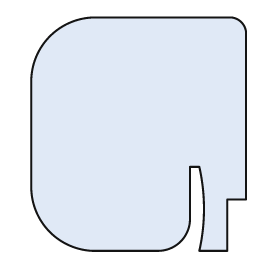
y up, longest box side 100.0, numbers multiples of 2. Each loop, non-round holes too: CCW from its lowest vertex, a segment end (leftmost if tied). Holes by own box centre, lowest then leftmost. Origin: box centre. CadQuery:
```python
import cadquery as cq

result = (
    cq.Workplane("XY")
    .moveTo(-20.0, -50.0)
    .lineTo(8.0, -50.0)
    .threePointArc((18.0, -46.0), (22.0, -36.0))
    .lineTo(22.0, -14.0)
    .lineTo(26.0, -14.0)
    .threePointArc((28.0, -32.0), (26.0, -50.0))
    .lineTo(38.0, -50.0)
    .lineTo(38.0, -28.0)
    .lineTo(46.0, -28.0)
    .lineTo(46.0, 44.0)
    .threePointArc((44.0, 48.0), (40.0, 50.0))
    .lineTo(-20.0, 50.0)
    .threePointArc((-38.0, 42.0), (-46.0, 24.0))
    .lineTo(-46.0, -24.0)
    .threePointArc((-38.0, -42.0), (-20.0, -50.0))
    .close()
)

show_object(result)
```